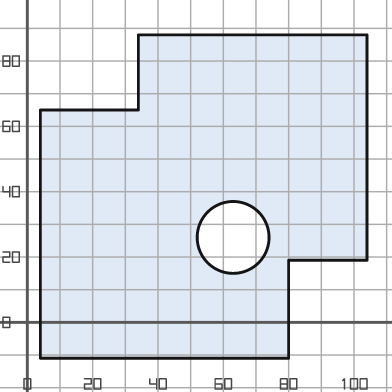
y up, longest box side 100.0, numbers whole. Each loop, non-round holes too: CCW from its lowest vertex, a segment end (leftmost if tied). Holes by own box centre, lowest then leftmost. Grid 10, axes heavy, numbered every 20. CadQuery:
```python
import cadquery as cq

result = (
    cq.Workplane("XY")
    .moveTo(4.0, -11.0)
    .lineTo(80.0, -11.0)
    .lineTo(80.0, 19.0)
    .lineTo(104.0, 19.0)
    .lineTo(104.0, 88.0)
    .lineTo(34.0, 88.0)
    .lineTo(34.0, 65.0)
    .lineTo(4.0, 65.0)
    .close()
    .moveTo(63.0, 26.0)
    .circle(11.0)
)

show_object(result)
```